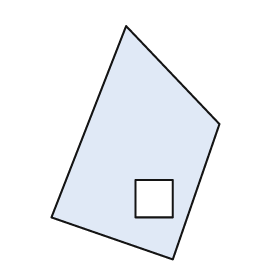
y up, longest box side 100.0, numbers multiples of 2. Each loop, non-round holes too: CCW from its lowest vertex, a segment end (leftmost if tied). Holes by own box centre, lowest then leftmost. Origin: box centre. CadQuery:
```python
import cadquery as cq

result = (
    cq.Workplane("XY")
    .moveTo(16.0, -50.0)
    .lineTo(36.0, 8.0)
    .lineTo(-4.0, 50.0)
    .lineTo(-36.0, -32.0)
    .close()
    .moveTo(0.0, -32.0)
    .lineTo(16.0, -32.0)
    .lineTo(16.0, -16.0)
    .lineTo(0.0, -16.0)
    .close()
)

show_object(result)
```